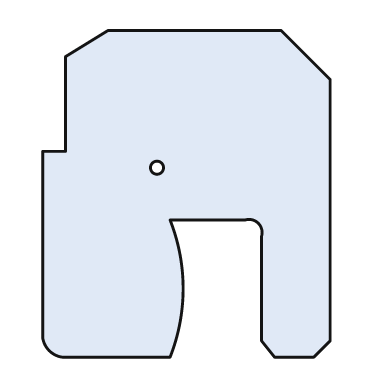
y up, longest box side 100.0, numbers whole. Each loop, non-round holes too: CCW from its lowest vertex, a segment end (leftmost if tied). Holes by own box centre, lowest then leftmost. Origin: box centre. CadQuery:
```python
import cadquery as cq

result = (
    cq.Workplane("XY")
    .moveTo(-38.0, -50.0)
    .lineTo(-5.0, -50.0)
    .threePointArc((-1.0, -29.0), (-5.0, -8.0))
    .lineTo(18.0, -8.0)
    .threePointArc((22.0, -9.0), (23.0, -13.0))
    .lineTo(23.0, -45.0)
    .lineTo(27.0, -50.0)
    .lineTo(39.0, -50.0)
    .lineTo(44.0, -45.0)
    .lineTo(44.0, 35.0)
    .lineTo(29.0, 50.0)
    .lineTo(-24.0, 50.0)
    .lineTo(-37.0, 42.0)
    .lineTo(-37.0, 13.0)
    .lineTo(-44.0, 13.0)
    .lineTo(-44.0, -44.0)
    .threePointArc((-42.0, -48.0), (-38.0, -50.0))
    .close()
    .moveTo(-9.0, 8.0)
    .circle(2.0)
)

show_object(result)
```